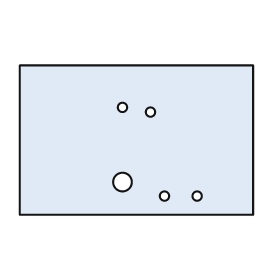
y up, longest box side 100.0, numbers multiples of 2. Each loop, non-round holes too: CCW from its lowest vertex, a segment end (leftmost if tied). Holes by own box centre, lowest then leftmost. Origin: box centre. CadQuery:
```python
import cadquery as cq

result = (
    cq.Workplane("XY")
    .moveTo(-50.0, -32.0)
    .lineTo(50.0, -32.0)
    .lineTo(50.0, 32.0)
    .lineTo(-50.0, 32.0)
    .close()
    .moveTo(12.0, -24.0)
    .circle(2.0)
    .moveTo(26.0, -24.0)
    .circle(2.0)
    .moveTo(-6.0, -18.0)
    .circle(4.0)
    .moveTo(6.0, 12.0)
    .circle(2.0)
    .moveTo(-6.0, 14.0)
    .circle(2.0)
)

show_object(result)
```